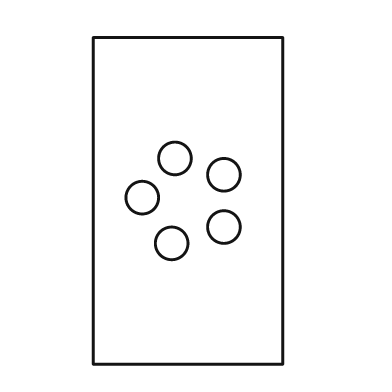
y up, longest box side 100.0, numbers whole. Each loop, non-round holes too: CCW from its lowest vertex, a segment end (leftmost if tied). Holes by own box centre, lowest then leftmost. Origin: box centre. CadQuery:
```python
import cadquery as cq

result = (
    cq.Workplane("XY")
    .moveTo(-29.0, -50.0)
    .lineTo(29.0, -50.0)
    .lineTo(29.0, 50.0)
    .lineTo(-29.0, 50.0)
    .close()
    .moveTo(-5.0, -13.0)
    .circle(5.0)
    .moveTo(11.0, -8.0)
    .circle(5.0)
    .moveTo(-14.0, 1.0)
    .circle(5.0)
    .moveTo(11.0, 8.0)
    .circle(5.0)
    .moveTo(-4.0, 13.0)
    .circle(5.0)
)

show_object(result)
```